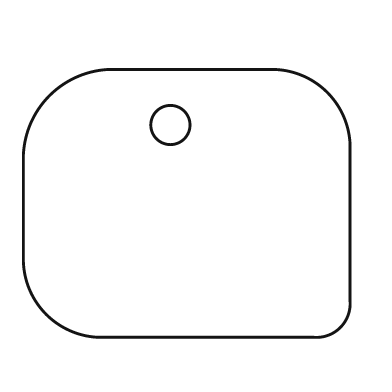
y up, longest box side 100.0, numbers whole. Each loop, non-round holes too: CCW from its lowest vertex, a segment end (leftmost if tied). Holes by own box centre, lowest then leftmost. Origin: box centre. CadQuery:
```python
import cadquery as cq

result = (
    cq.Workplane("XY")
    .moveTo(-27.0, -41.0)
    .lineTo(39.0, -41.0)
    .threePointArc((47.0, -38.0), (50.0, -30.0))
    .lineTo(50.0, 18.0)
    .threePointArc((43.0, 34.0), (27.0, 41.0))
    .lineTo(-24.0, 41.0)
    .threePointArc((-42.0, 33.0), (-50.0, 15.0))
    .lineTo(-50.0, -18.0)
    .threePointArc((-43.0, -34.0), (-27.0, -41.0))
    .close()
    .moveTo(-5.0, 24.0)
    .circle(6.0)
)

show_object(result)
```